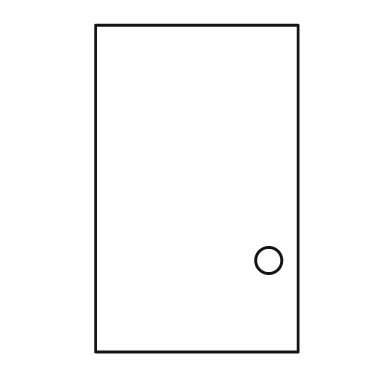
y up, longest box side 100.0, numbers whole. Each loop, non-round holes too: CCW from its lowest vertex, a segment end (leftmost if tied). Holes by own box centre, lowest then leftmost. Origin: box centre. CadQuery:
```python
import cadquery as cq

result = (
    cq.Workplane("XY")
    .moveTo(-31.0, -50.0)
    .lineTo(31.0, -50.0)
    .lineTo(31.0, 50.0)
    .lineTo(-31.0, 50.0)
    .close()
    .moveTo(22.0, -22.0)
    .circle(4.0)
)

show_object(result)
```